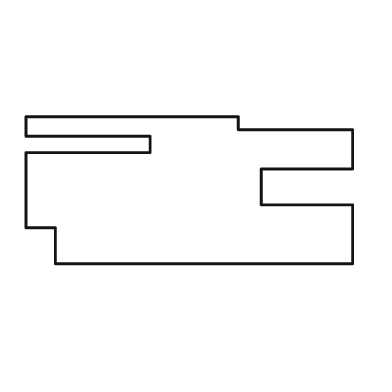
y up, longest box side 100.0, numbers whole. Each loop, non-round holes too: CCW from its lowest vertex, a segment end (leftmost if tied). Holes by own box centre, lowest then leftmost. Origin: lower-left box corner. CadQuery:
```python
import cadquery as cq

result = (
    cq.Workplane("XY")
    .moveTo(9.0, 0.0)
    .lineTo(100.0, 0.0)
    .lineTo(100.0, 18.0)
    .lineTo(72.0, 18.0)
    .lineTo(72.0, 29.0)
    .lineTo(100.0, 29.0)
    .lineTo(100.0, 41.0)
    .lineTo(65.0, 41.0)
    .lineTo(65.0, 45.0)
    .lineTo(0.0, 45.0)
    .lineTo(0.0, 39.0)
    .lineTo(38.0, 39.0)
    .lineTo(38.0, 34.0)
    .lineTo(0.0, 34.0)
    .lineTo(0.0, 11.0)
    .lineTo(9.0, 11.0)
    .close()
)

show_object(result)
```